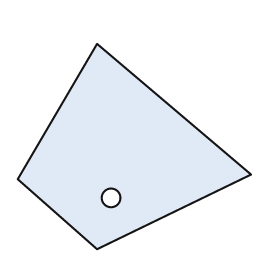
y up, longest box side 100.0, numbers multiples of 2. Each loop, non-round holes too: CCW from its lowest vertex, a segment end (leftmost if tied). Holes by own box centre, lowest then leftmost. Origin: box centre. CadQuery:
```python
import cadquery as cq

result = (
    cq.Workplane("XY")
    .moveTo(-16.0, -44.0)
    .lineTo(50.0, -12.0)
    .lineTo(-16.0, 44.0)
    .lineTo(-50.0, -14.0)
    .close()
    .moveTo(-10.0, -22.0)
    .circle(4.0)
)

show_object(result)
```